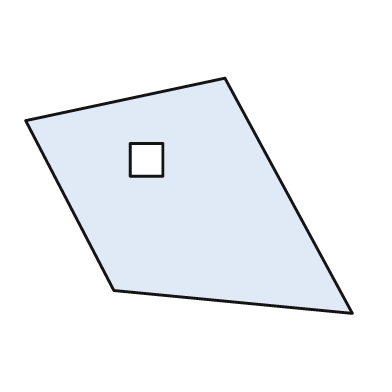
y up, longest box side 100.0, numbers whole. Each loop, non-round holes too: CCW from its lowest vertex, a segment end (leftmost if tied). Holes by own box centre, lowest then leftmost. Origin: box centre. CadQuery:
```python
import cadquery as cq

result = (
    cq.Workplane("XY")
    .moveTo(50.0, -36.0)
    .lineTo(11.0, 36.0)
    .lineTo(-50.0, 23.0)
    .lineTo(-23.0, -29.0)
    .close()
    .moveTo(-18.0, 6.0)
    .lineTo(-8.0, 6.0)
    .lineTo(-8.0, 16.0)
    .lineTo(-18.0, 16.0)
    .close()
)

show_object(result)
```